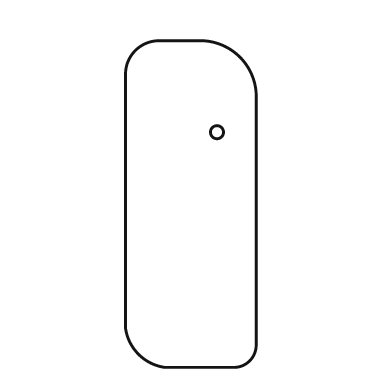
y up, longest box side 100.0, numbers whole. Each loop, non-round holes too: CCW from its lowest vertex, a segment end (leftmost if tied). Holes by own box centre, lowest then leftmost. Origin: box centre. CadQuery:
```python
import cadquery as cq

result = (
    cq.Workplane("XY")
    .moveTo(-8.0, -50.0)
    .lineTo(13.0, -50.0)
    .threePointArc((18.0, -48.0), (20.0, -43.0))
    .lineTo(20.0, 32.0)
    .threePointArc((15.0, 45.0), (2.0, 50.0))
    .lineTo(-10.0, 50.0)
    .threePointArc((-17.0, 47.0), (-20.0, 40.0))
    .lineTo(-20.0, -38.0)
    .threePointArc((-16.0, -46.0), (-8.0, -50.0))
    .close()
    .moveTo(8.0, 22.0)
    .circle(2.0)
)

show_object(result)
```